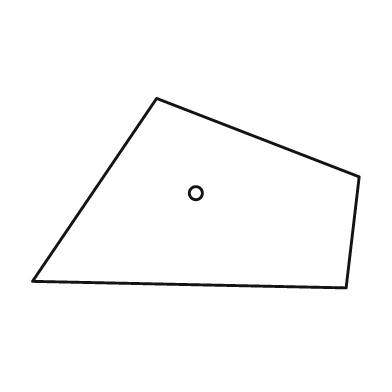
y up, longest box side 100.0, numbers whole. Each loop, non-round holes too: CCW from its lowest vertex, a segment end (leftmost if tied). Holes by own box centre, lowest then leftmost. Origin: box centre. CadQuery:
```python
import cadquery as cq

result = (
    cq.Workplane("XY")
    .moveTo(46.0, -29.0)
    .lineTo(50.0, 5.0)
    .lineTo(-12.0, 29.0)
    .lineTo(-50.0, -27.0)
    .close()
    .moveTo(0.0, 0.0)
    .circle(2.0)
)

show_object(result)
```